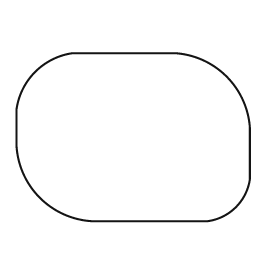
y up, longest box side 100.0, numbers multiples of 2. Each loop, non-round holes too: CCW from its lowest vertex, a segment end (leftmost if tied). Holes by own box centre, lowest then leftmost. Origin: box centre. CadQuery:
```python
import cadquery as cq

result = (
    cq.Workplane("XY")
    .moveTo(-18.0, -36.0)
    .lineTo(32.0, -36.0)
    .threePointArc((44.0, -30.0), (50.0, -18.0))
    .lineTo(50.0, 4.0)
    .threePointArc((40.0, 26.0), (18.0, 36.0))
    .lineTo(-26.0, 36.0)
    .threePointArc((-42.0, 28.0), (-50.0, 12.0))
    .lineTo(-50.0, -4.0)
    .threePointArc((-40.0, -26.0), (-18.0, -36.0))
    .close()
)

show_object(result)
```